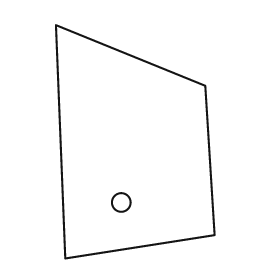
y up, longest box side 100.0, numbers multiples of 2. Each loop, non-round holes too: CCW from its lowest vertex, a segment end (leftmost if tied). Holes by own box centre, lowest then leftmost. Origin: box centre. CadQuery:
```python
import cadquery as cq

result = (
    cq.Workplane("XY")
    .moveTo(-30.0, -50.0)
    .lineTo(34.0, -40.0)
    .lineTo(30.0, 24.0)
    .lineTo(-34.0, 50.0)
    .close()
    .moveTo(-6.0, -26.0)
    .circle(4.0)
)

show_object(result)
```